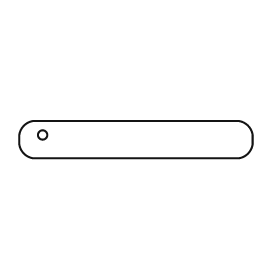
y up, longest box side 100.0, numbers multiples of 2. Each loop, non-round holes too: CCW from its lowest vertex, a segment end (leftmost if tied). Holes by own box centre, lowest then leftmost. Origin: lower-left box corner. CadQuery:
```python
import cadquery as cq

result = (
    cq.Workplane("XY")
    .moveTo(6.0, 0.0)
    .lineTo(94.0, 0.0)
    .threePointArc((98.0, 2.0), (100.0, 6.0))
    .lineTo(100.0, 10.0)
    .threePointArc((98.0, 14.0), (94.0, 16.0))
    .lineTo(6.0, 16.0)
    .threePointArc((2.0, 14.0), (0.0, 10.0))
    .lineTo(0.0, 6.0)
    .threePointArc((2.0, 2.0), (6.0, 0.0))
    .close()
    .moveTo(10.0, 10.0)
    .circle(2.0)
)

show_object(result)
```